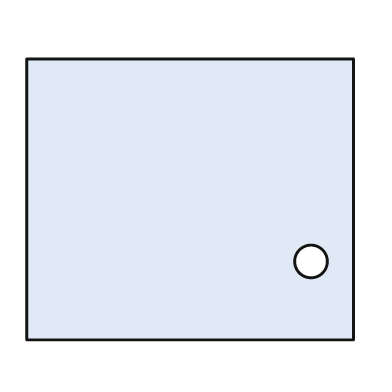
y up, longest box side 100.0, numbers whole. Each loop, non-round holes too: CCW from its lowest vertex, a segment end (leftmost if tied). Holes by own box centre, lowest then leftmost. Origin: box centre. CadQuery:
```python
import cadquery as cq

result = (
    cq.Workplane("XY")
    .moveTo(-50.0, -43.0)
    .lineTo(50.0, -43.0)
    .lineTo(50.0, 43.0)
    .lineTo(-50.0, 43.0)
    .close()
    .moveTo(37.0, -19.0)
    .circle(5.0)
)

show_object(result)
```